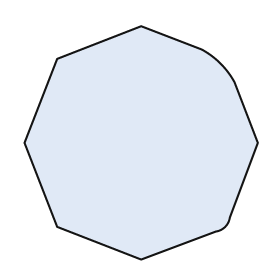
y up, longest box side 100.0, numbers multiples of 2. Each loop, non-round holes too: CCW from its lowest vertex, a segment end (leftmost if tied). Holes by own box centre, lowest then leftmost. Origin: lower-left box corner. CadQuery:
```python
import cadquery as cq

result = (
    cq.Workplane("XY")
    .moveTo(50.0, 0.0)
    .lineTo(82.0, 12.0)
    .threePointArc((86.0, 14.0), (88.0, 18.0))
    .lineTo(100.0, 50.0)
    .lineTo(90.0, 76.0)
    .threePointArc((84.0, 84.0), (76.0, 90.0))
    .lineTo(50.0, 100.0)
    .lineTo(14.0, 86.0)
    .lineTo(0.0, 50.0)
    .lineTo(14.0, 14.0)
    .close()
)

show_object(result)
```